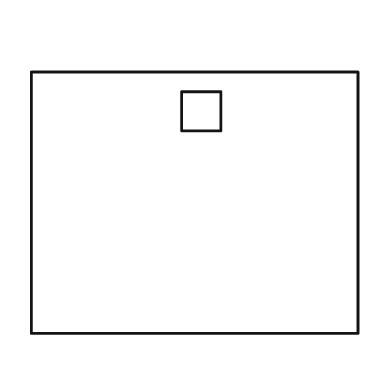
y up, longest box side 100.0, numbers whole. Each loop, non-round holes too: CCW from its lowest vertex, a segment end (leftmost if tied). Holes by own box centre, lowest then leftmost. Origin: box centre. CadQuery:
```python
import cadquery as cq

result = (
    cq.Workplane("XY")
    .moveTo(-50.0, -40.0)
    .lineTo(50.0, -40.0)
    .lineTo(50.0, 40.0)
    .lineTo(-50.0, 40.0)
    .close()
    .moveTo(-4.0, 22.0)
    .lineTo(8.0, 22.0)
    .lineTo(8.0, 34.0)
    .lineTo(-4.0, 34.0)
    .close()
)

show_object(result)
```